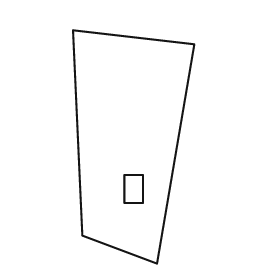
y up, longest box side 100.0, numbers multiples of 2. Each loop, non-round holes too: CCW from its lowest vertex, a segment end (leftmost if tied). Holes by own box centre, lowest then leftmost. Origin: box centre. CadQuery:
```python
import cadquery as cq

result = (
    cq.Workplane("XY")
    .moveTo(10.0, -50.0)
    .lineTo(26.0, 44.0)
    .lineTo(-26.0, 50.0)
    .lineTo(-22.0, -38.0)
    .close()
    .moveTo(-4.0, -24.0)
    .lineTo(4.0, -24.0)
    .lineTo(4.0, -12.0)
    .lineTo(-4.0, -12.0)
    .close()
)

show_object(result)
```